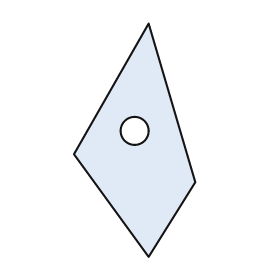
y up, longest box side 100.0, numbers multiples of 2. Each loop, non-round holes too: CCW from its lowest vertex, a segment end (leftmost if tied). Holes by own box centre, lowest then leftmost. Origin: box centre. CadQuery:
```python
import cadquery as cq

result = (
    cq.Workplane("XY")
    .moveTo(6.0, -50.0)
    .lineTo(26.0, -18.0)
    .lineTo(6.0, 50.0)
    .lineTo(-26.0, -6.0)
    .close()
    .moveTo(0.0, 4.0)
    .circle(6.0)
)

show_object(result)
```